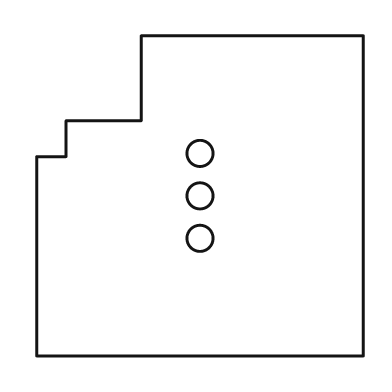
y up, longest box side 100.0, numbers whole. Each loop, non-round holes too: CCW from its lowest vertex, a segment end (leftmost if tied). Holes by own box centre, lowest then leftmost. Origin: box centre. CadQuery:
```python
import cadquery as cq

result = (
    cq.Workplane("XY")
    .moveTo(-50.0, -49.0)
    .lineTo(50.0, -49.0)
    .lineTo(50.0, 49.0)
    .lineTo(-18.0, 49.0)
    .lineTo(-18.0, 23.0)
    .lineTo(-41.0, 23.0)
    .lineTo(-41.0, 12.0)
    .lineTo(-50.0, 12.0)
    .close()
    .moveTo(0.0, -13.0)
    .circle(4.0)
    .moveTo(0.0, 0.0)
    .circle(4.0)
    .moveTo(0.0, 13.0)
    .circle(4.0)
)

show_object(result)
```